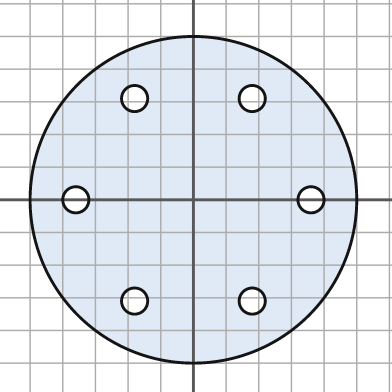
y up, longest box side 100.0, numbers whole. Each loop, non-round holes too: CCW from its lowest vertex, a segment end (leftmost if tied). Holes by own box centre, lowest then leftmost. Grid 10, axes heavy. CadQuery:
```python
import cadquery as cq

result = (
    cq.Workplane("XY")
    .moveTo(0.0, 0.0)
    .circle(50.0)
    .moveTo(-18.0, -31.0)
    .circle(4.0)
    .moveTo(18.0, -31.0)
    .circle(4.0)
    .moveTo(-36.0, 0.0)
    .circle(4.0)
    .moveTo(36.0, 0.0)
    .circle(4.0)
    .moveTo(-18.0, 31.0)
    .circle(4.0)
    .moveTo(18.0, 31.0)
    .circle(4.0)
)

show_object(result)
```